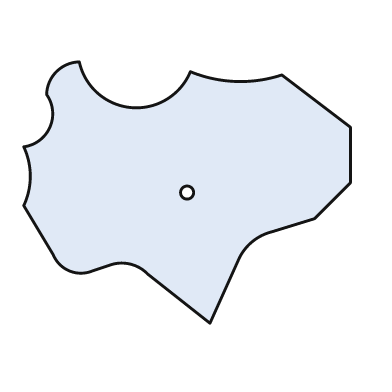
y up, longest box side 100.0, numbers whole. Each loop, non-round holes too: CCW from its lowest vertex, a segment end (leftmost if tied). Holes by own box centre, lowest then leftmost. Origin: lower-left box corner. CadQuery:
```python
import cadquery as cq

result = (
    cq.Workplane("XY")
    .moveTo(57.0, 0.0)
    .lineTo(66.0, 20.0)
    .threePointArc((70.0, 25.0), (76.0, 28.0))
    .lineTo(89.0, 32.0)
    .lineTo(100.0, 43.0)
    .lineTo(100.0, 60.0)
    .lineTo(79.0, 76.0)
    .threePointArc((65.0, 74.0), (51.0, 77.0))
    .threePointArc((33.0, 66.0), (17.0, 80.0))
    .threePointArc((10.0, 77.0), (7.0, 70.0))
    .threePointArc((8.0, 60.0), (0.0, 54.0))
    .threePointArc((2.0, 45.0), (0.0, 36.0))
    .lineTo(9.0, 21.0)
    .threePointArc((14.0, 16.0), (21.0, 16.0))
    .lineTo(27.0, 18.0)
    .threePointArc((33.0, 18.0), (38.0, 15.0))
    .close()
    .moveTo(50.0, 40.0)
    .circle(2.0)
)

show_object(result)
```